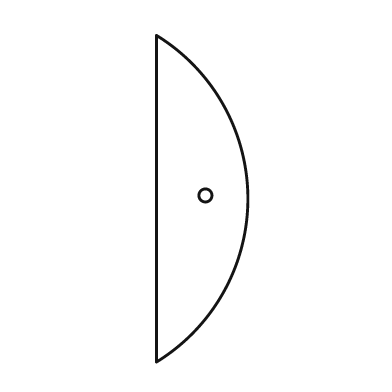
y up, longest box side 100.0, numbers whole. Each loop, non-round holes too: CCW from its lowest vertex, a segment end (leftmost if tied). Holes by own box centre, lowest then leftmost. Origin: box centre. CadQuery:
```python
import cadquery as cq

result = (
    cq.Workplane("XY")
    .moveTo(-14.0, -50.0)
    .threePointArc((14.0, 0.0), (-14.0, 50.0))
    .close()
    .moveTo(1.0, 1.0)
    .circle(2.0)
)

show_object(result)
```